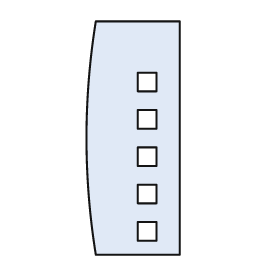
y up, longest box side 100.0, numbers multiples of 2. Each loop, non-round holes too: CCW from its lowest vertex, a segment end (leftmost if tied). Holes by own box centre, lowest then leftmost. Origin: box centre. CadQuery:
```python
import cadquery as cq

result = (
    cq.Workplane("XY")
    .moveTo(-16.0, -50.0)
    .lineTo(20.0, -50.0)
    .lineTo(20.0, 50.0)
    .lineTo(-16.0, 50.0)
    .threePointArc((-20.0, 0.0), (-16.0, -50.0))
    .close()
    .moveTo(2.0, -44.0)
    .lineTo(10.0, -44.0)
    .lineTo(10.0, -36.0)
    .lineTo(2.0, -36.0)
    .close()
    .moveTo(2.0, -28.0)
    .lineTo(10.0, -28.0)
    .lineTo(10.0, -20.0)
    .lineTo(2.0, -20.0)
    .close()
    .moveTo(2.0, -12.0)
    .lineTo(10.0, -12.0)
    .lineTo(10.0, -4.0)
    .lineTo(2.0, -4.0)
    .close()
    .moveTo(2.0, 4.0)
    .lineTo(10.0, 4.0)
    .lineTo(10.0, 12.0)
    .lineTo(2.0, 12.0)
    .close()
    .moveTo(2.0, 20.0)
    .lineTo(10.0, 20.0)
    .lineTo(10.0, 28.0)
    .lineTo(2.0, 28.0)
    .close()
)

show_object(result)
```